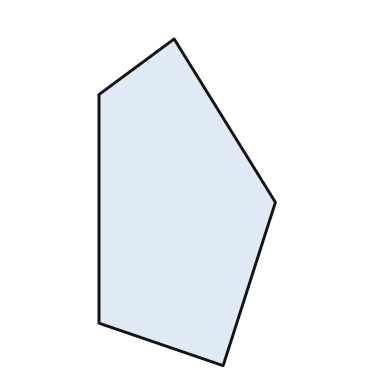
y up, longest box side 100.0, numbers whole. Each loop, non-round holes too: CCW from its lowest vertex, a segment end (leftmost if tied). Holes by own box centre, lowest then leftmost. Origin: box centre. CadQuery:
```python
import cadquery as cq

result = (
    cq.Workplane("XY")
    .moveTo(11.0, -50.0)
    .lineTo(27.0, 0.0)
    .lineTo(-4.0, 50.0)
    .lineTo(-27.0, 33.0)
    .lineTo(-27.0, -37.0)
    .close()
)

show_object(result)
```